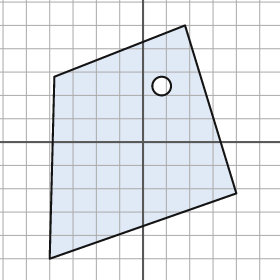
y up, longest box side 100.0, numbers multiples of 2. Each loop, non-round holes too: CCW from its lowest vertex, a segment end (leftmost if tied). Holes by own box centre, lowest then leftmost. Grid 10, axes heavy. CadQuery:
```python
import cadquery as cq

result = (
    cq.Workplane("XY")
    .moveTo(-40.0, -50.0)
    .lineTo(40.0, -22.0)
    .lineTo(18.0, 50.0)
    .lineTo(-38.0, 28.0)
    .close()
    .moveTo(8.0, 24.0)
    .circle(4.0)
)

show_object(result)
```